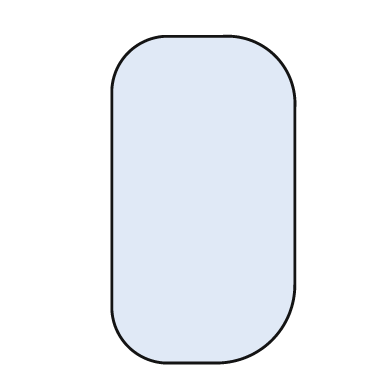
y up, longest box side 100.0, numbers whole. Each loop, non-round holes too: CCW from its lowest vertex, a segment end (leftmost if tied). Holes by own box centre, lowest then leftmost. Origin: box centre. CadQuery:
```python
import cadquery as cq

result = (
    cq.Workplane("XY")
    .moveTo(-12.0, -50.0)
    .lineTo(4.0, -50.0)
    .threePointArc((21.0, -43.0), (28.0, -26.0))
    .lineTo(28.0, 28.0)
    .threePointArc((22.0, 44.0), (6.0, 50.0))
    .lineTo(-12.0, 50.0)
    .threePointArc((-23.0, 45.0), (-28.0, 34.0))
    .lineTo(-28.0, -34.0)
    .threePointArc((-23.0, -45.0), (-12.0, -50.0))
    .close()
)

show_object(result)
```